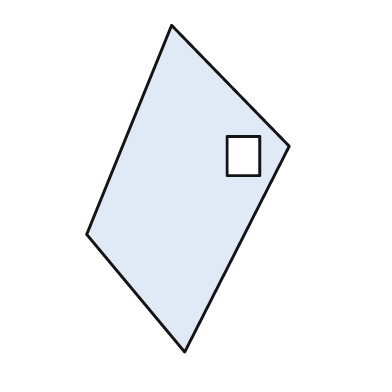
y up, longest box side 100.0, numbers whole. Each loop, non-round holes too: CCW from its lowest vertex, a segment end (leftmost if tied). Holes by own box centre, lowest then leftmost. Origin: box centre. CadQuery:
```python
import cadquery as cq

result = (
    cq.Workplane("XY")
    .moveTo(-1.0, -50.0)
    .lineTo(31.0, 13.0)
    .lineTo(-5.0, 50.0)
    .lineTo(-31.0, -14.0)
    .close()
    .moveTo(12.0, 4.0)
    .lineTo(22.0, 4.0)
    .lineTo(22.0, 16.0)
    .lineTo(12.0, 16.0)
    .close()
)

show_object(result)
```